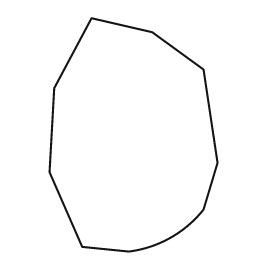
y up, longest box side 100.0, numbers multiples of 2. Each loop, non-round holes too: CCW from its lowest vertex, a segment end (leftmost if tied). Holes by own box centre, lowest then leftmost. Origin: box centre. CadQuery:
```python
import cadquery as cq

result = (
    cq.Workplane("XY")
    .moveTo(-2.0, -50.0)
    .threePointArc((16.0, -44.0), (30.0, -32.0))
    .lineTo(36.0, -12.0)
    .lineTo(30.0, 28.0)
    .lineTo(8.0, 44.0)
    .lineTo(-18.0, 50.0)
    .lineTo(-34.0, 20.0)
    .lineTo(-36.0, -16.0)
    .lineTo(-22.0, -48.0)
    .close()
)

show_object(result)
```